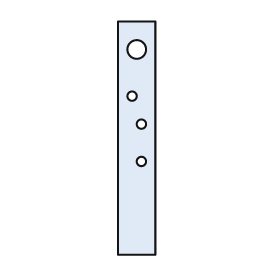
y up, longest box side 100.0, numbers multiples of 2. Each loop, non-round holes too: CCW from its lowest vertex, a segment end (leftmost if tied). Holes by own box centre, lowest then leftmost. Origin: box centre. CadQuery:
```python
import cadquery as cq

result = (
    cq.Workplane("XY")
    .moveTo(-8.0, -50.0)
    .lineTo(8.0, -50.0)
    .lineTo(8.0, 50.0)
    .lineTo(-8.0, 50.0)
    .close()
    .moveTo(2.0, -10.0)
    .circle(2.0)
    .moveTo(2.0, 6.0)
    .circle(2.0)
    .moveTo(-2.0, 18.0)
    .circle(2.0)
    .moveTo(0.0, 38.0)
    .circle(4.0)
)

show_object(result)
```